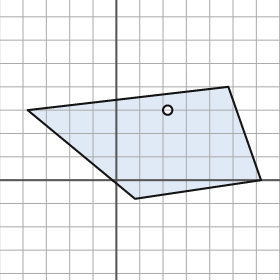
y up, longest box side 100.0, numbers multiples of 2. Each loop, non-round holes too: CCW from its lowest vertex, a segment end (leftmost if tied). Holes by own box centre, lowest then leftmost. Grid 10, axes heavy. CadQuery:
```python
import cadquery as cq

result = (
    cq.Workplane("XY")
    .moveTo(8.0, -8.0)
    .lineTo(62.0, 0.0)
    .lineTo(48.0, 40.0)
    .lineTo(-38.0, 30.0)
    .close()
    .moveTo(22.0, 30.0)
    .circle(2.0)
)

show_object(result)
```